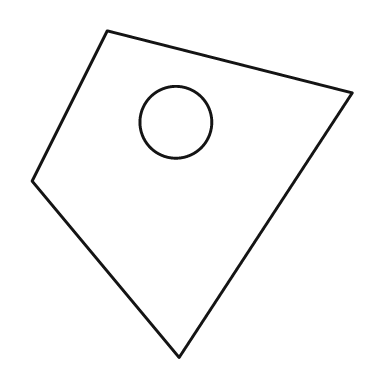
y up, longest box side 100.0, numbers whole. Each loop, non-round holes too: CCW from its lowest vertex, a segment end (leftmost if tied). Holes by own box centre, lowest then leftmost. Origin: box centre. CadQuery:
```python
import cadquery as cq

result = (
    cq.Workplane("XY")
    .moveTo(-4.0, -50.0)
    .lineTo(49.0, 31.0)
    .lineTo(-26.0, 50.0)
    .lineTo(-49.0, 4.0)
    .close()
    .moveTo(-5.0, 22.0)
    .circle(11.0)
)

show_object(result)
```